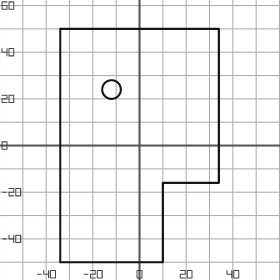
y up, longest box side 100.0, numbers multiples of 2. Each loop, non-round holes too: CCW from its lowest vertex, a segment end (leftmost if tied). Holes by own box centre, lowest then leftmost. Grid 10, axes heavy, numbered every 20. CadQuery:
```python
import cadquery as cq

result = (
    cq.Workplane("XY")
    .moveTo(-34.0, -50.0)
    .lineTo(10.0, -50.0)
    .lineTo(10.0, -16.0)
    .lineTo(34.0, -16.0)
    .lineTo(34.0, 50.0)
    .lineTo(-34.0, 50.0)
    .close()
    .moveTo(-12.0, 24.0)
    .circle(4.0)
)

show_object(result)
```